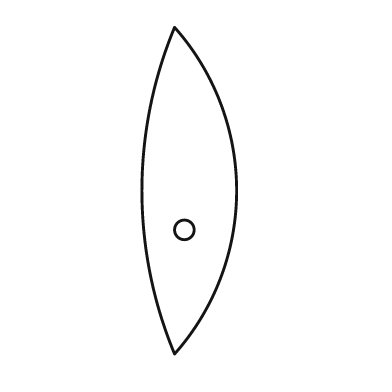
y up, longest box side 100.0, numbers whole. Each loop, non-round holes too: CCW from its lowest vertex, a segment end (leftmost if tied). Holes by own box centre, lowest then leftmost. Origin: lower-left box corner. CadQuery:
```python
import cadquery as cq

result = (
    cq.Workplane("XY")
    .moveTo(10.0, 0.0)
    .threePointArc((29.0, 50.0), (10.0, 100.0))
    .threePointArc((0.0, 50.0), (10.0, 0.0))
    .close()
    .moveTo(13.0, 38.0)
    .circle(3.0)
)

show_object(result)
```